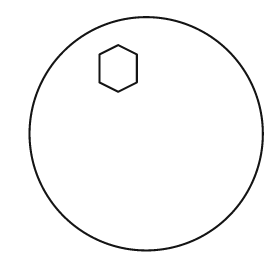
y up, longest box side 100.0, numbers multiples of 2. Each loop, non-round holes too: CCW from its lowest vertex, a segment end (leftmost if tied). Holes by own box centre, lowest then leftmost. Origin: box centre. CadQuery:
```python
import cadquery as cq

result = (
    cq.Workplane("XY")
    .moveTo(0.0, 0.0)
    .circle(50.0)
    .moveTo(-12.0, 18.0)
    .lineTo(-4.0, 22.0)
    .lineTo(-4.0, 34.0)
    .lineTo(-12.0, 38.0)
    .lineTo(-20.0, 34.0)
    .lineTo(-20.0, 22.0)
    .close()
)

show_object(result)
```